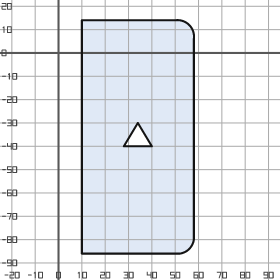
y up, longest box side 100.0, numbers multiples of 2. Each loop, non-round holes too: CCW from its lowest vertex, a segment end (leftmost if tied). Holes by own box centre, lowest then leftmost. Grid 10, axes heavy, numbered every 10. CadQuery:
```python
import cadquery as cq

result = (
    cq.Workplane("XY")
    .moveTo(10.0, -86.0)
    .lineTo(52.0, -86.0)
    .threePointArc((56.0, -84.0), (58.0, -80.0))
    .lineTo(58.0, 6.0)
    .threePointArc((56.0, 12.0), (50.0, 14.0))
    .lineTo(10.0, 14.0)
    .close()
    .moveTo(28.0, -40.0)
    .lineTo(40.0, -40.0)
    .lineTo(34.0, -30.0)
    .close()
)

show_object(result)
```